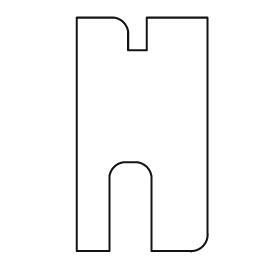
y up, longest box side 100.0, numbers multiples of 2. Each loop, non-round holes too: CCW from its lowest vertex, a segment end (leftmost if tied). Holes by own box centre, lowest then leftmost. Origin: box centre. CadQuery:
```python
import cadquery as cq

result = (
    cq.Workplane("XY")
    .moveTo(-28.0, -50.0)
    .lineTo(-14.0, -50.0)
    .lineTo(-14.0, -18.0)
    .threePointArc((-12.0, -14.0), (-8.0, -12.0))
    .lineTo(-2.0, -12.0)
    .threePointArc((2.0, -14.0), (4.0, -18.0))
    .lineTo(4.0, -50.0)
    .lineTo(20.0, -50.0)
    .threePointArc((26.0, -48.0), (28.0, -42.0))
    .lineTo(28.0, 50.0)
    .lineTo(2.0, 50.0)
    .lineTo(2.0, 36.0)
    .lineTo(-6.0, 36.0)
    .lineTo(-6.0, 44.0)
    .threePointArc((-8.0, 48.0), (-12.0, 50.0))
    .lineTo(-28.0, 50.0)
    .close()
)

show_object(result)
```